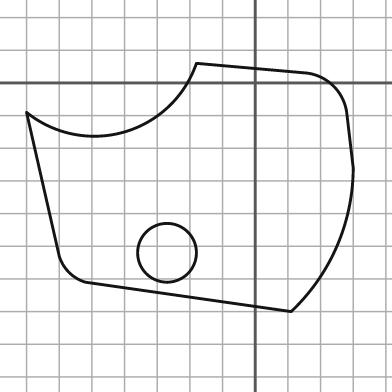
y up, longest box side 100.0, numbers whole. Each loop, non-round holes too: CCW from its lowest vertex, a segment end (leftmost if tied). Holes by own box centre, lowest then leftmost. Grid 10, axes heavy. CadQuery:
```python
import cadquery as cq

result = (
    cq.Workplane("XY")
    .moveTo(11.0, -70.0)
    .threePointArc((25.0, -50.0), (30.0, -26.0))
    .lineTo(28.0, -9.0)
    .threePointArc((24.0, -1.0), (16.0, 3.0))
    .lineTo(-18.0, 6.0)
    .threePointArc((-40.0, -15.0), (-70.0, -9.0))
    .lineTo(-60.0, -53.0)
    .threePointArc((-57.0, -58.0), (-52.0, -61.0))
    .close()
    .moveTo(-27.0, -52.0)
    .circle(9.0)
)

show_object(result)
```